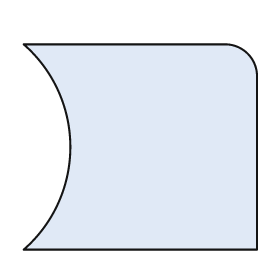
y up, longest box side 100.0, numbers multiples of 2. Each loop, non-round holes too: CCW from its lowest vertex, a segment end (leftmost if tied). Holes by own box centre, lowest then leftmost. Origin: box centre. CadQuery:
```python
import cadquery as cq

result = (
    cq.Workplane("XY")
    .moveTo(-50.0, -44.0)
    .lineTo(50.0, -44.0)
    .lineTo(50.0, 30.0)
    .threePointArc((46.0, 40.0), (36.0, 44.0))
    .lineTo(-50.0, 44.0)
    .threePointArc((-30.0, 0.0), (-50.0, -44.0))
    .close()
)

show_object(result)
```